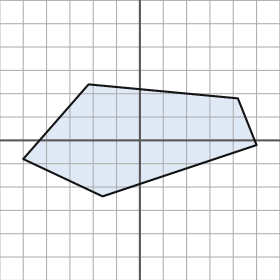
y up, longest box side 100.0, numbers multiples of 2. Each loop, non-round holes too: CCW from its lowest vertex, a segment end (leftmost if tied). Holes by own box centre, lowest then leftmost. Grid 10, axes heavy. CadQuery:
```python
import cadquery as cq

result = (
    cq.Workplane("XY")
    .moveTo(-16.0, -24.0)
    .lineTo(50.0, -2.0)
    .lineTo(42.0, 18.0)
    .lineTo(-22.0, 24.0)
    .lineTo(-50.0, -8.0)
    .close()
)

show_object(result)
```